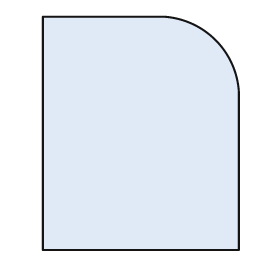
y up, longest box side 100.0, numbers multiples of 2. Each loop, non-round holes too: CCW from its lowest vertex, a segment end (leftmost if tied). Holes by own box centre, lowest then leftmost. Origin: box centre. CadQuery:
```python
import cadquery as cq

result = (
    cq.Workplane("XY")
    .moveTo(-42.0, -50.0)
    .lineTo(42.0, -50.0)
    .lineTo(42.0, 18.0)
    .threePointArc((32.0, 40.0), (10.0, 50.0))
    .lineTo(-42.0, 50.0)
    .close()
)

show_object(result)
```